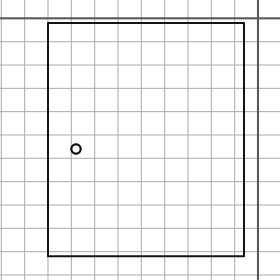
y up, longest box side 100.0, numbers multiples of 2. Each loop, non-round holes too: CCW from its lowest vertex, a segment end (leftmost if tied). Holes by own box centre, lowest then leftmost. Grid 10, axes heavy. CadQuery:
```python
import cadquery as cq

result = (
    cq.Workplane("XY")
    .moveTo(-90.0, -102.0)
    .lineTo(-6.0, -102.0)
    .lineTo(-6.0, -2.0)
    .lineTo(-90.0, -2.0)
    .close()
    .moveTo(-78.0, -56.0)
    .circle(2.0)
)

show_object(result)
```